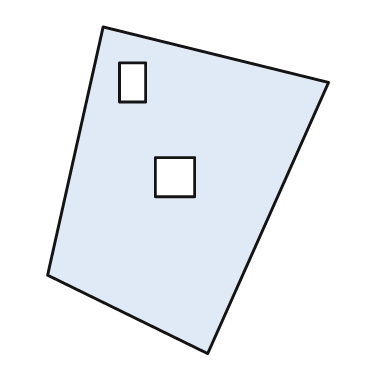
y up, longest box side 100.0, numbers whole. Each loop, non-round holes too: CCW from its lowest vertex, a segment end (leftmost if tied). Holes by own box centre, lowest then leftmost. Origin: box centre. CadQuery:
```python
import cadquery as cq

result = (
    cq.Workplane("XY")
    .moveTo(6.0, -50.0)
    .lineTo(43.0, 33.0)
    .lineTo(-26.0, 50.0)
    .lineTo(-43.0, -26.0)
    .close()
    .moveTo(-10.0, -2.0)
    .lineTo(2.0, -2.0)
    .lineTo(2.0, 10.0)
    .lineTo(-10.0, 10.0)
    .close()
    .moveTo(-21.0, 27.0)
    .lineTo(-13.0, 27.0)
    .lineTo(-13.0, 39.0)
    .lineTo(-21.0, 39.0)
    .close()
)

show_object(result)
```